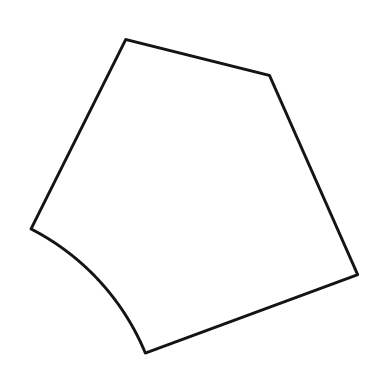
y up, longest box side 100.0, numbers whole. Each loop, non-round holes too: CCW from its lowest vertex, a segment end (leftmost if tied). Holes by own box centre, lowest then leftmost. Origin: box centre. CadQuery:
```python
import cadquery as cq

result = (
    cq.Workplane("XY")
    .moveTo(-15.0, -48.0)
    .lineTo(50.0, -24.0)
    .lineTo(23.0, 37.0)
    .lineTo(-21.0, 48.0)
    .lineTo(-50.0, -10.0)
    .threePointArc((-29.0, -26.0), (-15.0, -48.0))
    .close()
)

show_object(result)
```